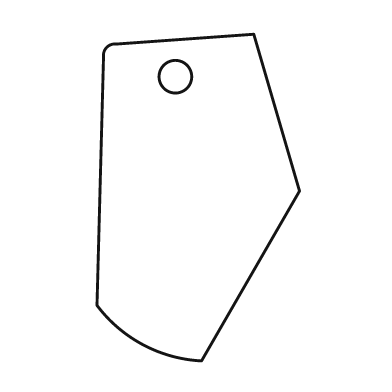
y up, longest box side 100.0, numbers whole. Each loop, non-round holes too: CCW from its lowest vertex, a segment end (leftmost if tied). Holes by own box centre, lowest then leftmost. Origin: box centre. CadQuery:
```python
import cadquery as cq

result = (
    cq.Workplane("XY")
    .moveTo(1.0, -50.0)
    .lineTo(31.0, 2.0)
    .lineTo(17.0, 50.0)
    .lineTo(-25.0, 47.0)
    .threePointArc((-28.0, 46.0), (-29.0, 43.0))
    .lineTo(-31.0, -33.0)
    .threePointArc((-17.0, -45.0), (1.0, -50.0))
    .close()
    .moveTo(-7.0, 37.0)
    .circle(5.0)
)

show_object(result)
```